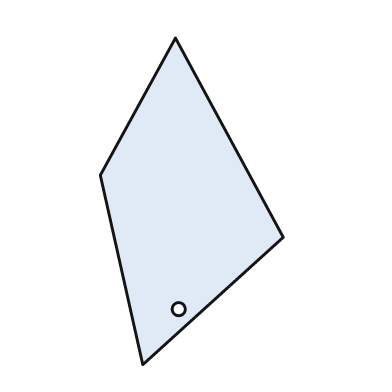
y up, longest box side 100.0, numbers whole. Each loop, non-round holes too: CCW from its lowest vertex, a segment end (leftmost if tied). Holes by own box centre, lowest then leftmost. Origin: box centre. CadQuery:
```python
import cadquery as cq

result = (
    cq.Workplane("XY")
    .moveTo(-15.0, -50.0)
    .lineTo(28.0, -11.0)
    .lineTo(-5.0, 50.0)
    .lineTo(-28.0, 8.0)
    .close()
    .moveTo(-4.0, -33.0)
    .circle(2.0)
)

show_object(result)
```